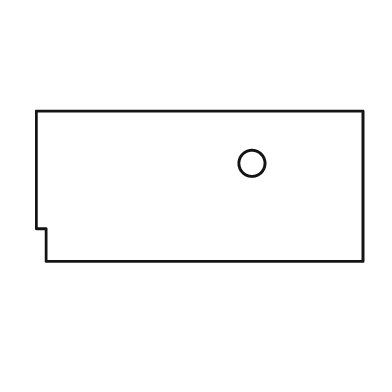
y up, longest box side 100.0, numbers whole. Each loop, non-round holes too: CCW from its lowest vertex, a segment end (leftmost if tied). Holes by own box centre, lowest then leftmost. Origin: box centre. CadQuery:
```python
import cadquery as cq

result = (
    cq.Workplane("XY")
    .moveTo(-47.0, -23.0)
    .lineTo(50.0, -23.0)
    .lineTo(50.0, 23.0)
    .lineTo(-50.0, 23.0)
    .lineTo(-50.0, -13.0)
    .lineTo(-47.0, -13.0)
    .close()
    .moveTo(16.0, 7.0)
    .circle(4.0)
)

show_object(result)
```